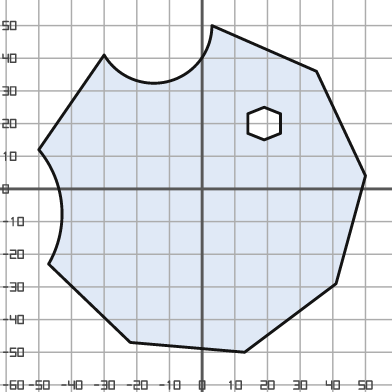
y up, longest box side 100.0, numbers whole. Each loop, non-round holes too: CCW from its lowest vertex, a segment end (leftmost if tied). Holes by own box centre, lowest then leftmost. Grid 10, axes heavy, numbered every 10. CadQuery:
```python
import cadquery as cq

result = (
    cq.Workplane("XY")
    .moveTo(13.0, -50.0)
    .lineTo(41.0, -29.0)
    .lineTo(50.0, 4.0)
    .lineTo(35.0, 36.0)
    .lineTo(3.0, 50.0)
    .threePointArc((-10.0, 33.0), (-30.0, 41.0))
    .lineTo(-50.0, 12.0)
    .threePointArc((-43.0, -5.0), (-47.0, -23.0))
    .lineTo(-22.0, -47.0)
    .close()
    .moveTo(19.0, 15.0)
    .lineTo(24.0, 17.0)
    .lineTo(24.0, 23.0)
    .lineTo(19.0, 25.0)
    .lineTo(14.0, 23.0)
    .lineTo(14.0, 17.0)
    .close()
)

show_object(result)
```